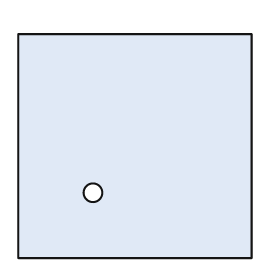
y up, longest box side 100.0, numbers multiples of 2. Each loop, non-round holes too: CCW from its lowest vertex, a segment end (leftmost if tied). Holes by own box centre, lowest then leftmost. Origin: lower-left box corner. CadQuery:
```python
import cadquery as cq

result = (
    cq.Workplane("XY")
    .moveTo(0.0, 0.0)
    .lineTo(100.0, 0.0)
    .lineTo(100.0, 96.0)
    .lineTo(0.0, 96.0)
    .close()
    .moveTo(32.0, 28.0)
    .circle(4.0)
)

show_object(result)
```